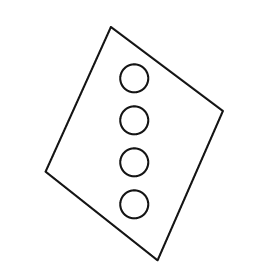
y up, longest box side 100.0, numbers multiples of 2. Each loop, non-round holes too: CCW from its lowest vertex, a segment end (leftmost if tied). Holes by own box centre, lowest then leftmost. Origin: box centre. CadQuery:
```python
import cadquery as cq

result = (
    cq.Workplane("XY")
    .moveTo(10.0, -50.0)
    .lineTo(38.0, 14.0)
    .lineTo(-10.0, 50.0)
    .lineTo(-38.0, -12.0)
    .close()
    .moveTo(0.0, -26.0)
    .circle(6.0)
    .moveTo(0.0, -8.0)
    .circle(6.0)
    .moveTo(0.0, 10.0)
    .circle(6.0)
    .moveTo(0.0, 28.0)
    .circle(6.0)
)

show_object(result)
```